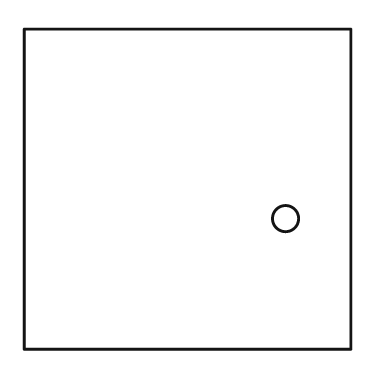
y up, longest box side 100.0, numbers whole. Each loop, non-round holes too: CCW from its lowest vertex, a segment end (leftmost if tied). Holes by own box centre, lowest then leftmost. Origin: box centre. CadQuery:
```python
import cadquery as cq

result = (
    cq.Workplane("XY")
    .moveTo(-50.0, -49.0)
    .lineTo(50.0, -49.0)
    .lineTo(50.0, 49.0)
    .lineTo(-50.0, 49.0)
    .close()
    .moveTo(30.0, -9.0)
    .circle(4.0)
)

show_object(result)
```